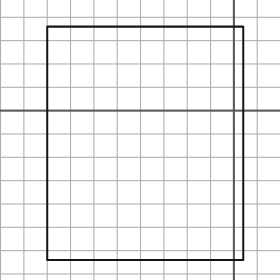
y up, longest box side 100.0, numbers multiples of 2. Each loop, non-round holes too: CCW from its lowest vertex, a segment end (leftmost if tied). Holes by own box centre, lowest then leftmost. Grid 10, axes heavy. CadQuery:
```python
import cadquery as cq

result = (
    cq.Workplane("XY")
    .moveTo(-80.0, -64.0)
    .lineTo(4.0, -64.0)
    .lineTo(4.0, 36.0)
    .lineTo(-80.0, 36.0)
    .close()
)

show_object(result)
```